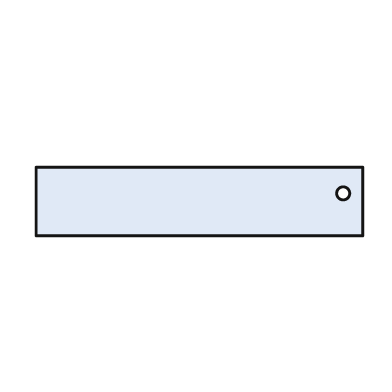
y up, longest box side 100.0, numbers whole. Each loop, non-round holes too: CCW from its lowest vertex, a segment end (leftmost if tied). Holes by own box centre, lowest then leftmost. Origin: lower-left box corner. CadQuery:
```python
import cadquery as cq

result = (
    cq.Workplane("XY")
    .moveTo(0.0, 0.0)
    .lineTo(100.0, 0.0)
    .lineTo(100.0, 21.0)
    .lineTo(0.0, 21.0)
    .close()
    .moveTo(94.0, 13.0)
    .circle(2.0)
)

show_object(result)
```